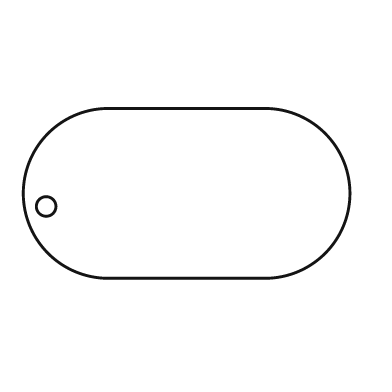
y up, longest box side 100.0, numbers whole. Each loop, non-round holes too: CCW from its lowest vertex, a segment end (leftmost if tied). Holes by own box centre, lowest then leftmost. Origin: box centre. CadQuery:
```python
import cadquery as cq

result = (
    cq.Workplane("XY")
    .moveTo(-24.0, -26.0)
    .lineTo(24.0, -26.0)
    .threePointArc((50.0, 0.0), (24.0, 26.0))
    .lineTo(-24.0, 26.0)
    .threePointArc((-50.0, 0.0), (-24.0, -26.0))
    .close()
    .moveTo(-43.0, -4.0)
    .circle(3.0)
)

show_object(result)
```